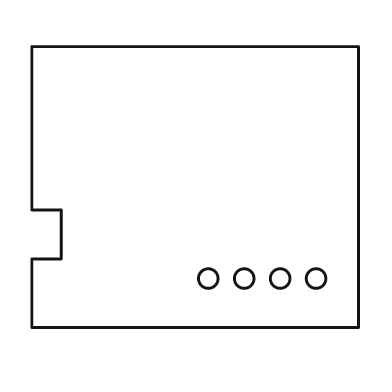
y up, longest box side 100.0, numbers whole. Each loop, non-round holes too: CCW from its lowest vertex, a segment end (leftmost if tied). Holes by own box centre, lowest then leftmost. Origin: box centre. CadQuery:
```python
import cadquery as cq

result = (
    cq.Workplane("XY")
    .moveTo(-50.0, -43.0)
    .lineTo(50.0, -43.0)
    .lineTo(50.0, 43.0)
    .lineTo(-50.0, 43.0)
    .lineTo(-50.0, -7.0)
    .lineTo(-41.0, -7.0)
    .lineTo(-41.0, -22.0)
    .lineTo(-50.0, -22.0)
    .close()
    .moveTo(4.0, -28.0)
    .circle(3.0)
    .moveTo(15.0, -28.0)
    .circle(3.0)
    .moveTo(26.0, -28.0)
    .circle(3.0)
    .moveTo(37.0, -28.0)
    .circle(3.0)
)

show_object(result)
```